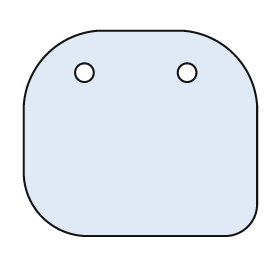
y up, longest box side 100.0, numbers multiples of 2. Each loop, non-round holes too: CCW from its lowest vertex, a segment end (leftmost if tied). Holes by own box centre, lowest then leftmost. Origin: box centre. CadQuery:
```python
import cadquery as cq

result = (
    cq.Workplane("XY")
    .moveTo(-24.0, -44.0)
    .lineTo(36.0, -44.0)
    .threePointArc((46.0, -40.0), (50.0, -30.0))
    .lineTo(50.0, 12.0)
    .threePointArc((40.0, 34.0), (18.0, 44.0))
    .lineTo(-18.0, 44.0)
    .threePointArc((-40.0, 34.0), (-50.0, 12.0))
    .lineTo(-50.0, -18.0)
    .threePointArc((-42.0, -36.0), (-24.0, -44.0))
    .close()
    .moveTo(-24.0, 26.0)
    .circle(4.0)
    .moveTo(20.0, 26.0)
    .circle(4.0)
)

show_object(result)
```